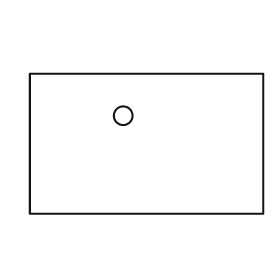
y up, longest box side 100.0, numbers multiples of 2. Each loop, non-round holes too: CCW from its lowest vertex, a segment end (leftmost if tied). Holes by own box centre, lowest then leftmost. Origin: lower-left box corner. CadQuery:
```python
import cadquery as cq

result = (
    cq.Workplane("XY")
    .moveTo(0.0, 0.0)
    .lineTo(100.0, 0.0)
    .lineTo(100.0, 60.0)
    .lineTo(0.0, 60.0)
    .close()
    .moveTo(40.0, 42.0)
    .circle(4.0)
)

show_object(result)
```